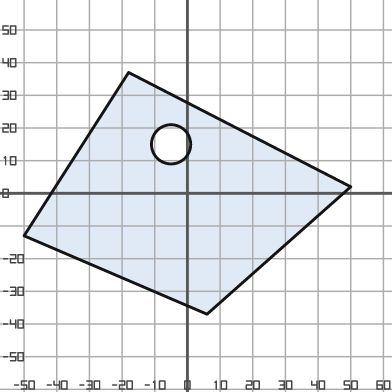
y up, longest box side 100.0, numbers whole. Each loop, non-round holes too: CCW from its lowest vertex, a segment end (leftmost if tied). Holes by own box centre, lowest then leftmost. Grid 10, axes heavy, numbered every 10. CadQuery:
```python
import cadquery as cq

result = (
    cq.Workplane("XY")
    .moveTo(6.0, -37.0)
    .lineTo(50.0, 2.0)
    .lineTo(-18.0, 37.0)
    .lineTo(-50.0, -13.0)
    .close()
    .moveTo(-5.0, 15.0)
    .circle(6.0)
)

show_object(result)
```